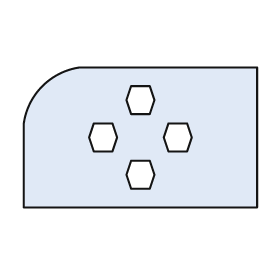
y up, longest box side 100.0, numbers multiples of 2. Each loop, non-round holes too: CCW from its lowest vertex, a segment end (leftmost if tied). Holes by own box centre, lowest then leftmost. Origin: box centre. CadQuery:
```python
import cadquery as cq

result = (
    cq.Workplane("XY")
    .moveTo(-50.0, -30.0)
    .lineTo(50.0, -30.0)
    .lineTo(50.0, 30.0)
    .lineTo(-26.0, 30.0)
    .threePointArc((-42.0, 22.0), (-50.0, 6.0))
    .close()
    .moveTo(-4.0, -22.0)
    .lineTo(4.0, -22.0)
    .lineTo(6.0, -16.0)
    .lineTo(4.0, -10.0)
    .lineTo(-4.0, -10.0)
    .lineTo(-6.0, -16.0)
    .close()
    .moveTo(-20.0, -6.0)
    .lineTo(-12.0, -6.0)
    .lineTo(-10.0, 0.0)
    .lineTo(-12.0, 6.0)
    .lineTo(-20.0, 6.0)
    .lineTo(-22.0, 0.0)
    .close()
    .moveTo(12.0, -6.0)
    .lineTo(20.0, -6.0)
    .lineTo(22.0, 0.0)
    .lineTo(20.0, 6.0)
    .lineTo(12.0, 6.0)
    .lineTo(10.0, 0.0)
    .close()
    .moveTo(-4.0, 10.0)
    .lineTo(4.0, 10.0)
    .lineTo(6.0, 16.0)
    .lineTo(4.0, 22.0)
    .lineTo(-4.0, 22.0)
    .lineTo(-6.0, 16.0)
    .close()
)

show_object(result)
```